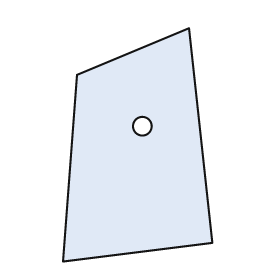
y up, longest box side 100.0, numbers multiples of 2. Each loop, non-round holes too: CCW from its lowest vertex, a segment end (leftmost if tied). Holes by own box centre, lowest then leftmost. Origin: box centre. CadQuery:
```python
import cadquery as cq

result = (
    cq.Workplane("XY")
    .moveTo(-32.0, -50.0)
    .lineTo(32.0, -42.0)
    .lineTo(22.0, 50.0)
    .lineTo(-26.0, 30.0)
    .close()
    .moveTo(2.0, 8.0)
    .circle(4.0)
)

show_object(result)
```